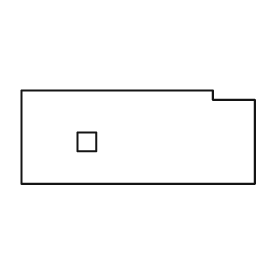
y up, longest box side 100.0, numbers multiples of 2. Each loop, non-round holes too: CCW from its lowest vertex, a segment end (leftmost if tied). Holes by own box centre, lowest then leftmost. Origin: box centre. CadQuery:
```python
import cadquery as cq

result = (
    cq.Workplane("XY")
    .moveTo(-50.0, -20.0)
    .lineTo(50.0, -20.0)
    .lineTo(50.0, 16.0)
    .lineTo(32.0, 16.0)
    .lineTo(32.0, 20.0)
    .lineTo(-50.0, 20.0)
    .close()
    .moveTo(-26.0, -6.0)
    .lineTo(-18.0, -6.0)
    .lineTo(-18.0, 2.0)
    .lineTo(-26.0, 2.0)
    .close()
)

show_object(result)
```